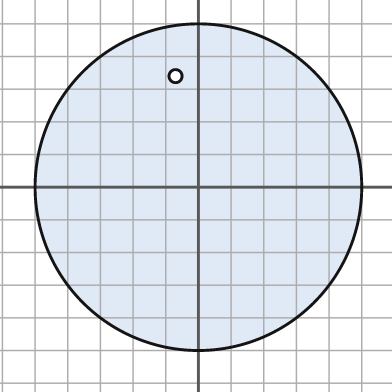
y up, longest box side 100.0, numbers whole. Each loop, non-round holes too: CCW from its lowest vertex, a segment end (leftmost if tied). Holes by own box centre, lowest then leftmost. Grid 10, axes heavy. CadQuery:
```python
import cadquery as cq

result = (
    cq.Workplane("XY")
    .moveTo(0.0, 0.0)
    .circle(50.0)
    .moveTo(-7.0, 34.0)
    .circle(2.0)
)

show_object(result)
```